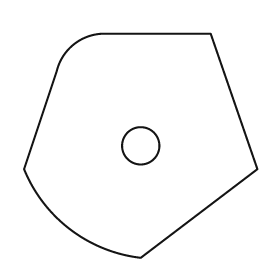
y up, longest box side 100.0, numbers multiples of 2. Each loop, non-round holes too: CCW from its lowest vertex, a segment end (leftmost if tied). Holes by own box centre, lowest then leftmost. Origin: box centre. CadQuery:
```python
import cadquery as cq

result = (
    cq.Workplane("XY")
    .moveTo(0.0, -48.0)
    .lineTo(50.0, -10.0)
    .lineTo(30.0, 48.0)
    .lineTo(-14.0, 48.0)
    .threePointArc((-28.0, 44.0), (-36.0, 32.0))
    .lineTo(-50.0, -10.0)
    .threePointArc((-30.0, -36.0), (0.0, -48.0))
    .close()
    .moveTo(0.0, 0.0)
    .circle(8.0)
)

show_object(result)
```